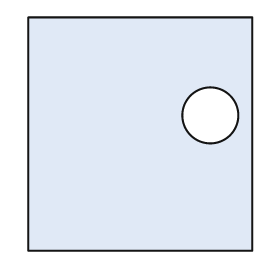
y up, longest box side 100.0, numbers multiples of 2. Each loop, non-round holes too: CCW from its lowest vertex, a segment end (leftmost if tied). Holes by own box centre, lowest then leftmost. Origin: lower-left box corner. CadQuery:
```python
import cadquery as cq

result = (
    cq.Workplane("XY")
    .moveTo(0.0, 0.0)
    .lineTo(96.0, 0.0)
    .lineTo(96.0, 100.0)
    .lineTo(0.0, 100.0)
    .close()
    .moveTo(78.0, 58.0)
    .circle(12.0)
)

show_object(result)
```